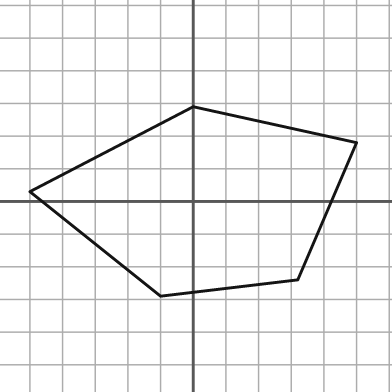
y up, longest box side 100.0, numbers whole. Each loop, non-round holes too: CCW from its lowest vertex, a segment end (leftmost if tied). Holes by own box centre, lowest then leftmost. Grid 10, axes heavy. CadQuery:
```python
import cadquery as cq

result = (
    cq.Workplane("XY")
    .moveTo(-10.0, -29.0)
    .lineTo(32.0, -24.0)
    .lineTo(50.0, 18.0)
    .lineTo(0.0, 29.0)
    .lineTo(-50.0, 3.0)
    .close()
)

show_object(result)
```